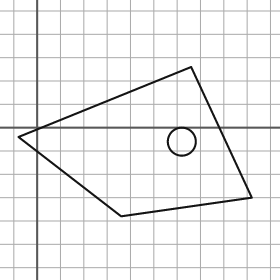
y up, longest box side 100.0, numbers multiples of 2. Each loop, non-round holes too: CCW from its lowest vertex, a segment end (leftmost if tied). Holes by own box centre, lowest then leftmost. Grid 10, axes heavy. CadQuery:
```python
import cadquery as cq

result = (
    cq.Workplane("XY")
    .moveTo(36.0, -38.0)
    .lineTo(92.0, -30.0)
    .lineTo(66.0, 26.0)
    .lineTo(-8.0, -4.0)
    .close()
    .moveTo(62.0, -6.0)
    .circle(6.0)
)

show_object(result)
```